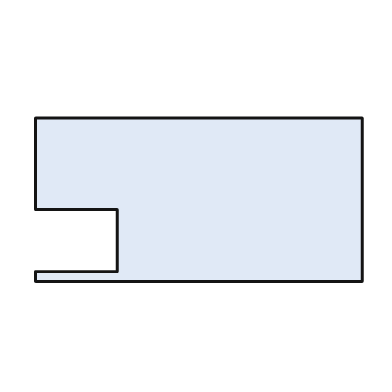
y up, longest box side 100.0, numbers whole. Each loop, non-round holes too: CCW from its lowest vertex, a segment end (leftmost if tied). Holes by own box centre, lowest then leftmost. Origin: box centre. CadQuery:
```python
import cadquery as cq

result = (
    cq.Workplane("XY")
    .moveTo(-50.0, -25.0)
    .lineTo(50.0, -25.0)
    .lineTo(50.0, 25.0)
    .lineTo(-50.0, 25.0)
    .lineTo(-50.0, -3.0)
    .lineTo(-25.0, -3.0)
    .lineTo(-25.0, -22.0)
    .lineTo(-50.0, -22.0)
    .close()
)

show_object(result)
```